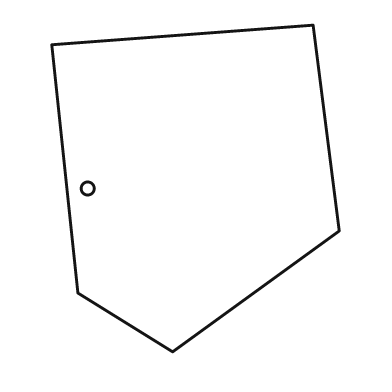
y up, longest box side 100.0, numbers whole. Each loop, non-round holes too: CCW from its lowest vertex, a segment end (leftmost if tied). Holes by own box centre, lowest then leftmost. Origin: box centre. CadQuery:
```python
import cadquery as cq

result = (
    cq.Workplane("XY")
    .moveTo(-7.0, -50.0)
    .lineTo(44.0, -13.0)
    .lineTo(36.0, 50.0)
    .lineTo(-44.0, 44.0)
    .lineTo(-36.0, -32.0)
    .close()
    .moveTo(-33.0, 0.0)
    .circle(2.0)
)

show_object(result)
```